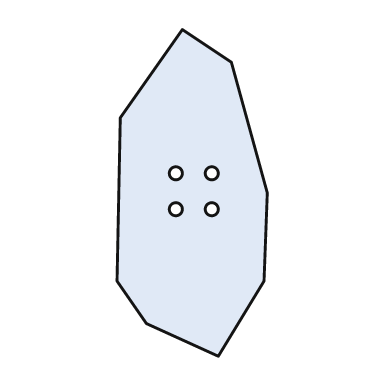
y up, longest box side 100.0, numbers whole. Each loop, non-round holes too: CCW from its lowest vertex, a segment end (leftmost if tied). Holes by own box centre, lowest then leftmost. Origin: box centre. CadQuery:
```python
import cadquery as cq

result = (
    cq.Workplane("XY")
    .moveTo(8.0, -50.0)
    .lineTo(22.0, -27.0)
    .lineTo(23.0, 0.0)
    .lineTo(12.0, 40.0)
    .lineTo(-3.0, 50.0)
    .lineTo(-22.0, 23.0)
    .lineTo(-23.0, -27.0)
    .lineTo(-14.0, -40.0)
    .close()
    .moveTo(-5.0, -5.0)
    .circle(2.0)
    .moveTo(6.0, -5.0)
    .circle(2.0)
    .moveTo(-5.0, 6.0)
    .circle(2.0)
    .moveTo(6.0, 6.0)
    .circle(2.0)
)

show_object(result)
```